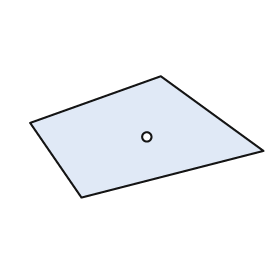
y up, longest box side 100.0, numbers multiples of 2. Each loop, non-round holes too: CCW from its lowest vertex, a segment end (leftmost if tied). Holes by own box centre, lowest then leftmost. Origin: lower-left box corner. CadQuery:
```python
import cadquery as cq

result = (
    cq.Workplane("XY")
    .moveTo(22.0, 0.0)
    .lineTo(100.0, 20.0)
    .lineTo(56.0, 52.0)
    .lineTo(0.0, 32.0)
    .close()
    .moveTo(50.0, 26.0)
    .circle(2.0)
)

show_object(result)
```